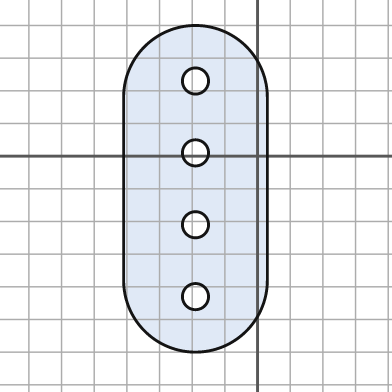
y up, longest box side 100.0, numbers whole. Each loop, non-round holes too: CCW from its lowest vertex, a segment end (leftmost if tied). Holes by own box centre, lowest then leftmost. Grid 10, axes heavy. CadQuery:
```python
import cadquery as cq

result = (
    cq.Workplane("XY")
    .moveTo(-41.0, -38.0)
    .threePointArc((-19.0, -60.0), (3.0, -38.0))
    .lineTo(3.0, 18.0)
    .threePointArc((-19.0, 40.0), (-41.0, 18.0))
    .close()
    .moveTo(-19.0, -43.0)
    .circle(4.0)
    .moveTo(-19.0, -21.0)
    .circle(4.0)
    .moveTo(-19.0, 1.0)
    .circle(4.0)
    .moveTo(-19.0, 23.0)
    .circle(4.0)
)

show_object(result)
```